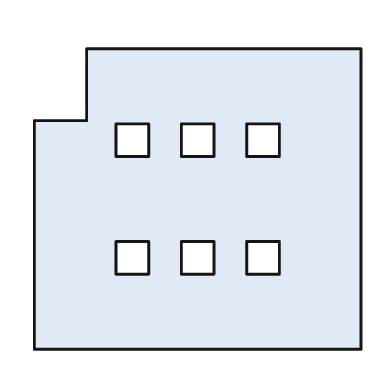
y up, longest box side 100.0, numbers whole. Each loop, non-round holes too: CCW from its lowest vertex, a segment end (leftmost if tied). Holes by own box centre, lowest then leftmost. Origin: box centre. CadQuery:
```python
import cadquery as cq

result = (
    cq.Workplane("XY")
    .moveTo(-50.0, -46.0)
    .lineTo(50.0, -46.0)
    .lineTo(50.0, 46.0)
    .lineTo(-34.0, 46.0)
    .lineTo(-34.0, 24.0)
    .lineTo(-50.0, 24.0)
    .close()
    .moveTo(-25.0, -23.0)
    .lineTo(-15.0, -23.0)
    .lineTo(-15.0, -13.0)
    .lineTo(-25.0, -13.0)
    .close()
    .moveTo(-5.0, -23.0)
    .lineTo(5.0, -23.0)
    .lineTo(5.0, -13.0)
    .lineTo(-5.0, -13.0)
    .close()
    .moveTo(15.0, -23.0)
    .lineTo(25.0, -23.0)
    .lineTo(25.0, -13.0)
    .lineTo(15.0, -13.0)
    .close()
    .moveTo(-25.0, 13.0)
    .lineTo(-15.0, 13.0)
    .lineTo(-15.0, 23.0)
    .lineTo(-25.0, 23.0)
    .close()
    .moveTo(-5.0, 13.0)
    .lineTo(5.0, 13.0)
    .lineTo(5.0, 23.0)
    .lineTo(-5.0, 23.0)
    .close()
    .moveTo(15.0, 13.0)
    .lineTo(25.0, 13.0)
    .lineTo(25.0, 23.0)
    .lineTo(15.0, 23.0)
    .close()
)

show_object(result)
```